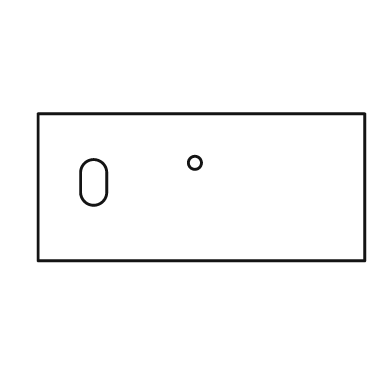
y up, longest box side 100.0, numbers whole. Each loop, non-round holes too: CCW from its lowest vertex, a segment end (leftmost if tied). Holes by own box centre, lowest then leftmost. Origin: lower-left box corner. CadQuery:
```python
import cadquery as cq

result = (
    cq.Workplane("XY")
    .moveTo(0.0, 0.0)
    .lineTo(100.0, 0.0)
    .lineTo(100.0, 45.0)
    .lineTo(0.0, 45.0)
    .close()
    .moveTo(13.0, 21.0)
    .threePointArc((17.0, 17.0), (21.0, 21.0))
    .lineTo(21.0, 27.0)
    .threePointArc((17.0, 31.0), (13.0, 27.0))
    .close()
    .moveTo(48.0, 30.0)
    .circle(2.0)
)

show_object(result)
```